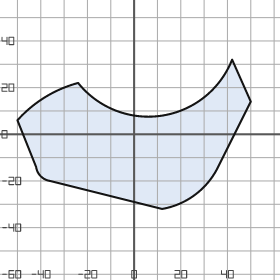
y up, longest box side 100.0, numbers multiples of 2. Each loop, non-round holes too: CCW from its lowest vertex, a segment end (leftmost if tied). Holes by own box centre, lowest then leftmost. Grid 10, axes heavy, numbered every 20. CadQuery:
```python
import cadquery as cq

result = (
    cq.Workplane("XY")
    .moveTo(12.0, -32.0)
    .threePointArc((26.0, -26.0), (36.0, -14.0))
    .lineTo(50.0, 14.0)
    .lineTo(42.0, 32.0)
    .threePointArc((12.0, 8.0), (-24.0, 22.0))
    .threePointArc((-38.0, 16.0), (-50.0, 6.0))
    .lineTo(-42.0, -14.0)
    .threePointArc((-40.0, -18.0), (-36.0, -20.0))
    .close()
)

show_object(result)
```